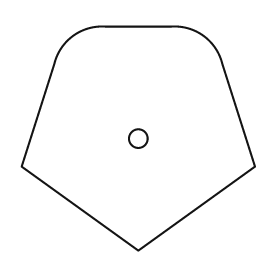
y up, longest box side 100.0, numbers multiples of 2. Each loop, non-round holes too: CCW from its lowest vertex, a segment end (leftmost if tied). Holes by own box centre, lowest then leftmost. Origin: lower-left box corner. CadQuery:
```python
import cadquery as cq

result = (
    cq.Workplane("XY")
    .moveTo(50.0, 0.0)
    .lineTo(100.0, 36.0)
    .lineTo(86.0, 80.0)
    .threePointArc((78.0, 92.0), (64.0, 96.0))
    .lineTo(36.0, 96.0)
    .threePointArc((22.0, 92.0), (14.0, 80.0))
    .lineTo(0.0, 36.0)
    .close()
    .moveTo(50.0, 48.0)
    .circle(4.0)
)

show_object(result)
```